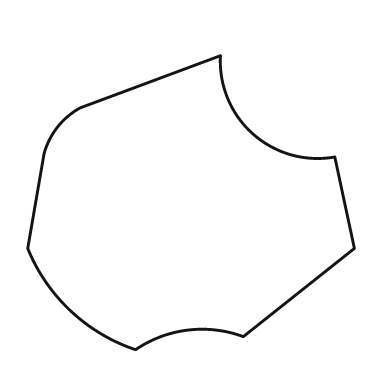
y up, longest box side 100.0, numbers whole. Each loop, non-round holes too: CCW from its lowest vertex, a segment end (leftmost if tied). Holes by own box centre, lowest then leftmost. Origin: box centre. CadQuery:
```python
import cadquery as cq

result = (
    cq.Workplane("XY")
    .moveTo(-17.0, -45.0)
    .threePointArc((-1.0, -39.0), (16.0, -41.0))
    .lineTo(50.0, -14.0)
    .lineTo(44.0, 14.0)
    .threePointArc((19.0, 21.0), (9.0, 45.0))
    .lineTo(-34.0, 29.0)
    .threePointArc((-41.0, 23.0), (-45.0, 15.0))
    .lineTo(-50.0, -14.0)
    .threePointArc((-37.0, -33.0), (-17.0, -45.0))
    .close()
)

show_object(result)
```